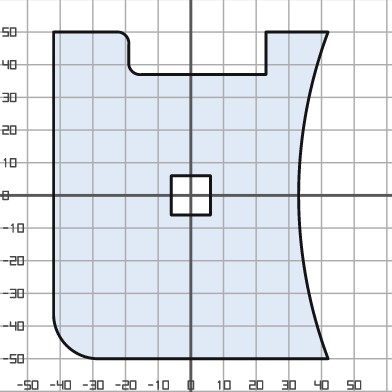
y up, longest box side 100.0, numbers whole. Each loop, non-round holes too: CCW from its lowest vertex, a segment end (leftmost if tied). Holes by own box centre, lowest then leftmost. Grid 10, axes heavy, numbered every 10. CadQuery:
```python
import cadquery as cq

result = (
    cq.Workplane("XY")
    .moveTo(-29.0, -50.0)
    .lineTo(42.0, -50.0)
    .threePointArc((33.0, 0.0), (42.0, 50.0))
    .lineTo(23.0, 50.0)
    .lineTo(23.0, 37.0)
    .lineTo(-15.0, 37.0)
    .threePointArc((-18.0, 38.0), (-19.0, 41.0))
    .lineTo(-19.0, 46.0)
    .threePointArc((-20.0, 49.0), (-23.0, 50.0))
    .lineTo(-42.0, 50.0)
    .lineTo(-42.0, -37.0)
    .threePointArc((-38.0, -46.0), (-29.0, -50.0))
    .close()
    .moveTo(-6.0, -6.0)
    .lineTo(6.0, -6.0)
    .lineTo(6.0, 6.0)
    .lineTo(-6.0, 6.0)
    .close()
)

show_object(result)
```